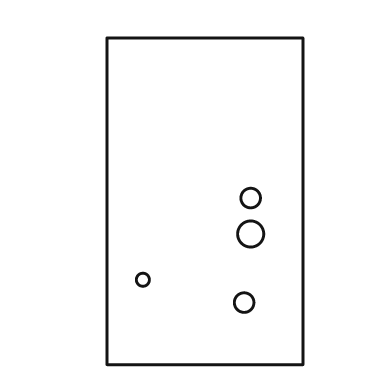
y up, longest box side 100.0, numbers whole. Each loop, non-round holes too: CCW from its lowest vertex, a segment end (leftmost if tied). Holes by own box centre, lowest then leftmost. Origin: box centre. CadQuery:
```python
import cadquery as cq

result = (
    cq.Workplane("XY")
    .moveTo(-30.0, -50.0)
    .lineTo(30.0, -50.0)
    .lineTo(30.0, 50.0)
    .lineTo(-30.0, 50.0)
    .close()
    .moveTo(12.0, -31.0)
    .circle(3.0)
    .moveTo(-19.0, -24.0)
    .circle(2.0)
    .moveTo(14.0, -10.0)
    .circle(4.0)
    .moveTo(14.0, 1.0)
    .circle(3.0)
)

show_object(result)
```